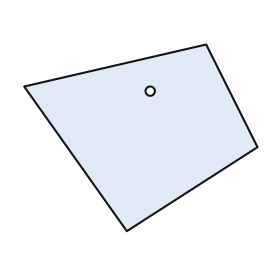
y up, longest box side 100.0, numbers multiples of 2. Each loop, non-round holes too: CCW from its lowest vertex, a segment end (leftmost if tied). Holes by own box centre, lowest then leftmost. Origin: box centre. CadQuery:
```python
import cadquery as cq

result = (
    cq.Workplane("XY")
    .moveTo(-6.0, -40.0)
    .lineTo(50.0, -4.0)
    .lineTo(28.0, 40.0)
    .lineTo(-50.0, 22.0)
    .close()
    .moveTo(4.0, 20.0)
    .circle(2.0)
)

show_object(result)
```